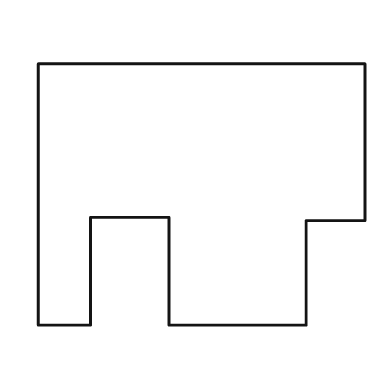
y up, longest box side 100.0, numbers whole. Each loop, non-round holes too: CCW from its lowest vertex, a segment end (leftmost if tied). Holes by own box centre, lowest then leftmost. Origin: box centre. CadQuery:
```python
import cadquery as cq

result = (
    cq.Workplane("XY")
    .moveTo(-50.0, -40.0)
    .lineTo(-34.0, -40.0)
    .lineTo(-34.0, -7.0)
    .lineTo(-10.0, -7.0)
    .lineTo(-10.0, -40.0)
    .lineTo(32.0, -40.0)
    .lineTo(32.0, -8.0)
    .lineTo(50.0, -8.0)
    .lineTo(50.0, 40.0)
    .lineTo(-50.0, 40.0)
    .close()
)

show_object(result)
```